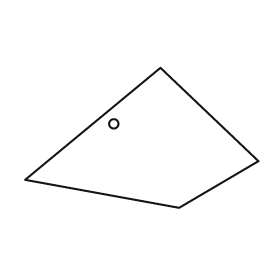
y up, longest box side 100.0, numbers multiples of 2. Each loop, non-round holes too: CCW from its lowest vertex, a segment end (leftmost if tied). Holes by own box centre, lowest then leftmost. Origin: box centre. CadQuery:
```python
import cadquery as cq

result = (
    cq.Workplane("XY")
    .moveTo(16.0, -30.0)
    .lineTo(50.0, -10.0)
    .lineTo(8.0, 30.0)
    .lineTo(-50.0, -18.0)
    .close()
    .moveTo(-12.0, 6.0)
    .circle(2.0)
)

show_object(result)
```